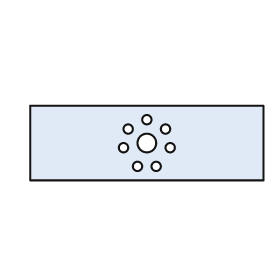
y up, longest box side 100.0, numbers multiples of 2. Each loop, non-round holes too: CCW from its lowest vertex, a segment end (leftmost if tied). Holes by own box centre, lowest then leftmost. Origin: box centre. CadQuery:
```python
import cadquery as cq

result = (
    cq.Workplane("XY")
    .moveTo(-50.0, -16.0)
    .lineTo(50.0, -16.0)
    .lineTo(50.0, 16.0)
    .lineTo(-50.0, 16.0)
    .close()
    .moveTo(-4.0, -10.0)
    .circle(2.0)
    .moveTo(4.0, -10.0)
    .circle(2.0)
    .moveTo(-10.0, -2.0)
    .circle(2.0)
    .moveTo(10.0, -2.0)
    .circle(2.0)
    .moveTo(0.0, 0.0)
    .circle(4.0)
    .moveTo(-8.0, 6.0)
    .circle(2.0)
    .moveTo(8.0, 6.0)
    .circle(2.0)
    .moveTo(0.0, 10.0)
    .circle(2.0)
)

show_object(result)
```